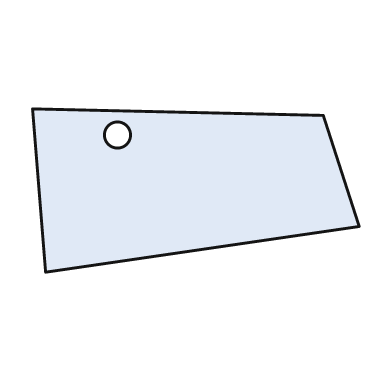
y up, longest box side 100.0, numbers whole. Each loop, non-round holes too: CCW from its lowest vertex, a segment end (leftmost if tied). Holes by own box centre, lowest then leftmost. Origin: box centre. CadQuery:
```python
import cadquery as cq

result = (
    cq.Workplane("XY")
    .moveTo(-46.0, -25.0)
    .lineTo(50.0, -11.0)
    .lineTo(39.0, 23.0)
    .lineTo(-50.0, 25.0)
    .close()
    .moveTo(-24.0, 17.0)
    .circle(4.0)
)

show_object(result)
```